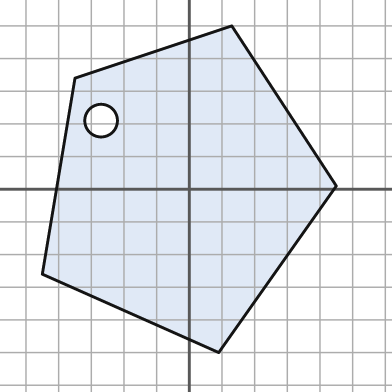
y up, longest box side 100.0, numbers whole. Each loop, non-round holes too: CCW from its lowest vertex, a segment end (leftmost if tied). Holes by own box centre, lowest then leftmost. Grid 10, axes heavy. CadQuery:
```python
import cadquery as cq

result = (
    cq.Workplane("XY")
    .moveTo(9.0, -50.0)
    .lineTo(45.0, 1.0)
    .lineTo(13.0, 50.0)
    .lineTo(-35.0, 34.0)
    .lineTo(-45.0, -26.0)
    .close()
    .moveTo(-27.0, 21.0)
    .circle(5.0)
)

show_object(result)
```